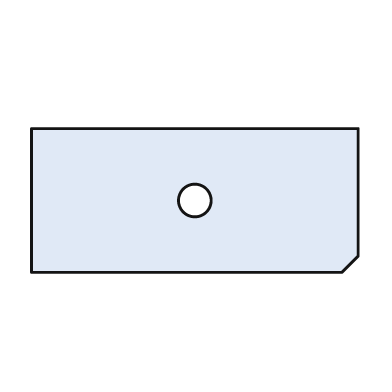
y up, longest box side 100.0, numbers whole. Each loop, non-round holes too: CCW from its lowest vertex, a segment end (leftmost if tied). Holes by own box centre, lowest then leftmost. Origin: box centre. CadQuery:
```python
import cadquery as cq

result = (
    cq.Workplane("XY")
    .moveTo(-50.0, -22.0)
    .lineTo(45.0, -22.0)
    .lineTo(50.0, -17.0)
    .lineTo(50.0, 22.0)
    .lineTo(-50.0, 22.0)
    .close()
    .moveTo(0.0, 0.0)
    .circle(5.0)
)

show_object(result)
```